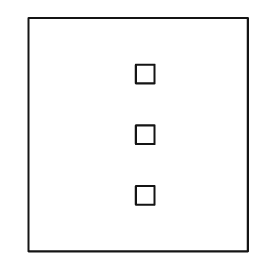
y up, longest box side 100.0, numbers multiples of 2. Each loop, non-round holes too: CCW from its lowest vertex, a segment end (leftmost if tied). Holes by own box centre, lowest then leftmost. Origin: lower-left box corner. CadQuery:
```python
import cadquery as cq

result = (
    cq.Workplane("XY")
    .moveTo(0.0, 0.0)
    .lineTo(94.0, 0.0)
    .lineTo(94.0, 100.0)
    .lineTo(0.0, 100.0)
    .close()
    .moveTo(46.0, 20.0)
    .lineTo(54.0, 20.0)
    .lineTo(54.0, 28.0)
    .lineTo(46.0, 28.0)
    .close()
    .moveTo(46.0, 46.0)
    .lineTo(54.0, 46.0)
    .lineTo(54.0, 54.0)
    .lineTo(46.0, 54.0)
    .close()
    .moveTo(46.0, 72.0)
    .lineTo(54.0, 72.0)
    .lineTo(54.0, 80.0)
    .lineTo(46.0, 80.0)
    .close()
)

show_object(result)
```